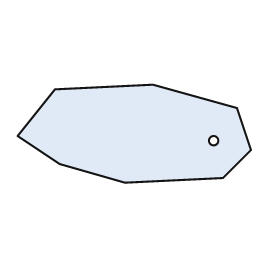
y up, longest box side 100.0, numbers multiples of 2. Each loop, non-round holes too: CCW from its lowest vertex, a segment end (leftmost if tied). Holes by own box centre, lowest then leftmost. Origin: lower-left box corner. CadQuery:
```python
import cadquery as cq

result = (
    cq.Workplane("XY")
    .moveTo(46.0, 0.0)
    .lineTo(88.0, 2.0)
    .lineTo(100.0, 14.0)
    .lineTo(94.0, 32.0)
    .lineTo(58.0, 42.0)
    .lineTo(16.0, 40.0)
    .lineTo(0.0, 20.0)
    .lineTo(18.0, 8.0)
    .close()
    .moveTo(84.0, 18.0)
    .circle(2.0)
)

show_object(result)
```